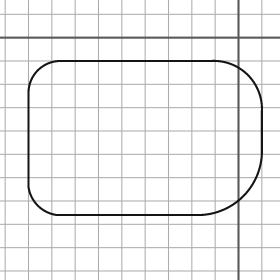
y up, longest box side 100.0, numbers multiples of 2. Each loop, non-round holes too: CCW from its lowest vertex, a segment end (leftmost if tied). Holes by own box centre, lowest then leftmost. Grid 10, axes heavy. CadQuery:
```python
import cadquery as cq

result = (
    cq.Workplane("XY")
    .moveTo(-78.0, -76.0)
    .lineTo(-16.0, -76.0)
    .threePointArc((2.0, -68.0), (10.0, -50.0))
    .lineTo(10.0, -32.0)
    .threePointArc((4.0, -16.0), (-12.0, -10.0))
    .lineTo(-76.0, -10.0)
    .threePointArc((-86.0, -14.0), (-90.0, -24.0))
    .lineTo(-90.0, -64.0)
    .threePointArc((-86.0, -72.0), (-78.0, -76.0))
    .close()
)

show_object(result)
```